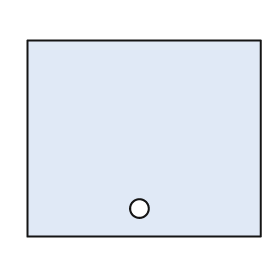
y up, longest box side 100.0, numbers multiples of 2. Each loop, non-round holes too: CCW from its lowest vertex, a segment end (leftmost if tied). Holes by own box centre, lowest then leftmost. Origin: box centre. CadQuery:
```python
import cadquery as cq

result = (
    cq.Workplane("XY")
    .moveTo(-50.0, -42.0)
    .lineTo(50.0, -42.0)
    .lineTo(50.0, 42.0)
    .lineTo(-50.0, 42.0)
    .close()
    .moveTo(-2.0, -30.0)
    .circle(4.0)
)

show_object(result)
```